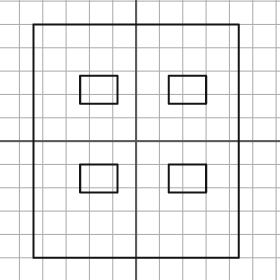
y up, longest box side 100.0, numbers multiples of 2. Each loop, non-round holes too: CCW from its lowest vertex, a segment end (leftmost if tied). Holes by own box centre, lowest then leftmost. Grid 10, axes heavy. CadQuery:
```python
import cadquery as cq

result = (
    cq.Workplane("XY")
    .moveTo(-44.0, -50.0)
    .lineTo(44.0, -50.0)
    .lineTo(44.0, 50.0)
    .lineTo(-44.0, 50.0)
    .close()
    .moveTo(-24.0, -22.0)
    .lineTo(-8.0, -22.0)
    .lineTo(-8.0, -10.0)
    .lineTo(-24.0, -10.0)
    .close()
    .moveTo(14.0, -22.0)
    .lineTo(30.0, -22.0)
    .lineTo(30.0, -10.0)
    .lineTo(14.0, -10.0)
    .close()
    .moveTo(-24.0, 16.0)
    .lineTo(-8.0, 16.0)
    .lineTo(-8.0, 28.0)
    .lineTo(-24.0, 28.0)
    .close()
    .moveTo(14.0, 16.0)
    .lineTo(30.0, 16.0)
    .lineTo(30.0, 28.0)
    .lineTo(14.0, 28.0)
    .close()
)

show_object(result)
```